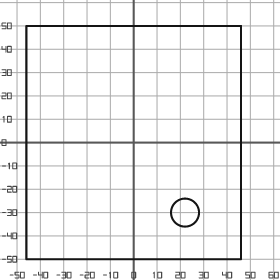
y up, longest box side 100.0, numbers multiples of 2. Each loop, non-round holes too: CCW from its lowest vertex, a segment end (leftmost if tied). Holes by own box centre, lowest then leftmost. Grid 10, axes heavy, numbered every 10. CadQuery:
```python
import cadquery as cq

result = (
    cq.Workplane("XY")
    .moveTo(-46.0, -50.0)
    .lineTo(46.0, -50.0)
    .lineTo(46.0, 50.0)
    .lineTo(-46.0, 50.0)
    .close()
    .moveTo(22.0, -30.0)
    .circle(6.0)
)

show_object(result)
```